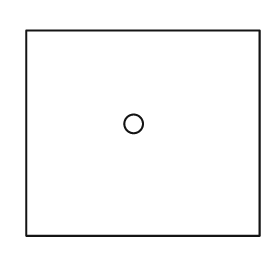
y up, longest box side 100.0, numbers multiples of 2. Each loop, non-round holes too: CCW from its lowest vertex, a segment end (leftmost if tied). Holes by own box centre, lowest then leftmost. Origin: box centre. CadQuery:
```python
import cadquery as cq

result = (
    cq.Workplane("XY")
    .moveTo(-50.0, -44.0)
    .lineTo(50.0, -44.0)
    .lineTo(50.0, 44.0)
    .lineTo(-50.0, 44.0)
    .close()
    .moveTo(-4.0, 4.0)
    .circle(4.0)
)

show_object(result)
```